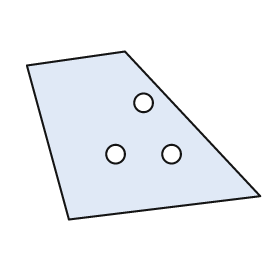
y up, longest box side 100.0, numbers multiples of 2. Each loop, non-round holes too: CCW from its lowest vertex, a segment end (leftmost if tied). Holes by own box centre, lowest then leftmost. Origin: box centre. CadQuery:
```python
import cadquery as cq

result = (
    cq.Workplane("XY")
    .moveTo(-32.0, -36.0)
    .lineTo(50.0, -26.0)
    .lineTo(-8.0, 36.0)
    .lineTo(-50.0, 30.0)
    .close()
    .moveTo(-12.0, -8.0)
    .circle(4.0)
    .moveTo(12.0, -8.0)
    .circle(4.0)
    .moveTo(0.0, 14.0)
    .circle(4.0)
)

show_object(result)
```